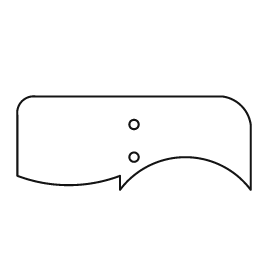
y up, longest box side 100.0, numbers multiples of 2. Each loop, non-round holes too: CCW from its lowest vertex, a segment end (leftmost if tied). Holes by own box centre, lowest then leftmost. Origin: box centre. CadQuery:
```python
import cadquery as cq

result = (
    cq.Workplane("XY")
    .moveTo(-6.0, -20.0)
    .threePointArc((22.0, -6.0), (50.0, -20.0))
    .lineTo(50.0, 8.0)
    .threePointArc((46.0, 16.0), (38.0, 20.0))
    .lineTo(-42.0, 20.0)
    .threePointArc((-48.0, 18.0), (-50.0, 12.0))
    .lineTo(-50.0, -14.0)
    .threePointArc((-28.0, -18.0), (-6.0, -14.0))
    .close()
    .moveTo(0.0, -6.0)
    .circle(2.0)
    .moveTo(0.0, 8.0)
    .circle(2.0)
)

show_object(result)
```